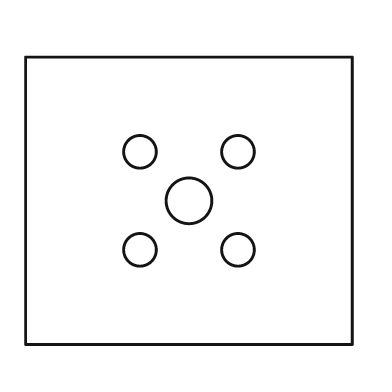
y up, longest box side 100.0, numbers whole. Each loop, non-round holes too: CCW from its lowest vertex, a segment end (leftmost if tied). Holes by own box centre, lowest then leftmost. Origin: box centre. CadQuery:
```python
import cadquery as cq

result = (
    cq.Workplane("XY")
    .moveTo(-50.0, -44.0)
    .lineTo(50.0, -44.0)
    .lineTo(50.0, 44.0)
    .lineTo(-50.0, 44.0)
    .close()
    .moveTo(-15.0, -15.0)
    .circle(5.0)
    .moveTo(15.0, -15.0)
    .circle(5.0)
    .moveTo(0.0, 0.0)
    .circle(7.0)
    .moveTo(-15.0, 15.0)
    .circle(5.0)
    .moveTo(15.0, 15.0)
    .circle(5.0)
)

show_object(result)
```